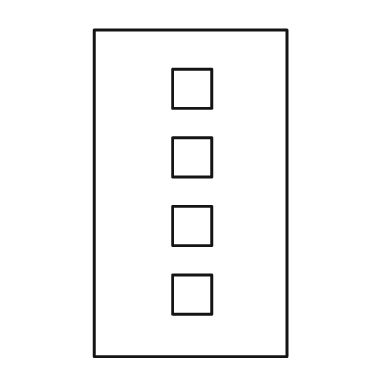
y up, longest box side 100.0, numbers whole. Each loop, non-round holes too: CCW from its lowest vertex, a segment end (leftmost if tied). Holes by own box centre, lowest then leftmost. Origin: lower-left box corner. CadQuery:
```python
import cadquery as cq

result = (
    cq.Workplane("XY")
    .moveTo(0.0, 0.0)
    .lineTo(59.0, 0.0)
    .lineTo(59.0, 100.0)
    .lineTo(0.0, 100.0)
    .close()
    .moveTo(24.0, 13.0)
    .lineTo(36.0, 13.0)
    .lineTo(36.0, 25.0)
    .lineTo(24.0, 25.0)
    .close()
    .moveTo(24.0, 34.0)
    .lineTo(36.0, 34.0)
    .lineTo(36.0, 46.0)
    .lineTo(24.0, 46.0)
    .close()
    .moveTo(24.0, 55.0)
    .lineTo(36.0, 55.0)
    .lineTo(36.0, 67.0)
    .lineTo(24.0, 67.0)
    .close()
    .moveTo(24.0, 76.0)
    .lineTo(36.0, 76.0)
    .lineTo(36.0, 88.0)
    .lineTo(24.0, 88.0)
    .close()
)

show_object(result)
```